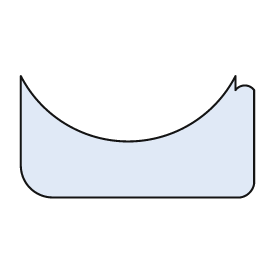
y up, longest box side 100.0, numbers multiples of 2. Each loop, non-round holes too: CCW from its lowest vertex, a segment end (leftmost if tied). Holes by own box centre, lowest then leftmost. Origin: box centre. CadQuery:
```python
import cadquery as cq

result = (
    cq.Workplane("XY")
    .moveTo(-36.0, -26.0)
    .lineTo(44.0, -26.0)
    .threePointArc((48.0, -24.0), (50.0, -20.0))
    .lineTo(50.0, 20.0)
    .threePointArc((46.0, 22.0), (42.0, 20.0))
    .lineTo(42.0, 26.0)
    .threePointArc((-4.0, -2.0), (-50.0, 26.0))
    .lineTo(-50.0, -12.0)
    .threePointArc((-46.0, -22.0), (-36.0, -26.0))
    .close()
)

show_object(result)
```